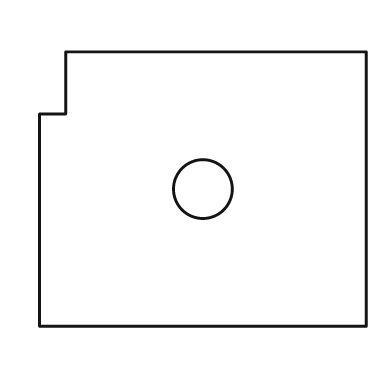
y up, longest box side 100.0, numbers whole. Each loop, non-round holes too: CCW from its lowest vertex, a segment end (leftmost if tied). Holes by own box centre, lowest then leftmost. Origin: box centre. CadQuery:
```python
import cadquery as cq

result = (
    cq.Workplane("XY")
    .moveTo(-50.0, -42.0)
    .lineTo(50.0, -42.0)
    .lineTo(50.0, 42.0)
    .lineTo(-42.0, 42.0)
    .lineTo(-42.0, 23.0)
    .lineTo(-50.0, 23.0)
    .close()
    .moveTo(0.0, 0.0)
    .circle(9.0)
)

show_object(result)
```